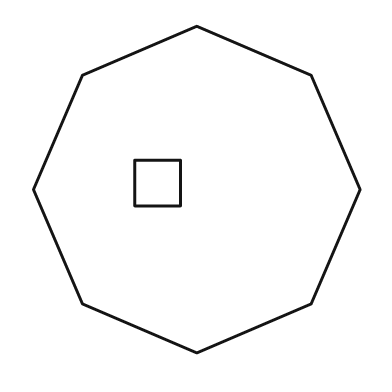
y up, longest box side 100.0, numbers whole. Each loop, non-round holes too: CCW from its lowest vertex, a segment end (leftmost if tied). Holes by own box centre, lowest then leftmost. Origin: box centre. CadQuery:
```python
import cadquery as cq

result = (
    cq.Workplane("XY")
    .moveTo(0.0, -50.0)
    .lineTo(35.0, -35.0)
    .lineTo(50.0, 0.0)
    .lineTo(35.0, 35.0)
    .lineTo(0.0, 50.0)
    .lineTo(-35.0, 35.0)
    .lineTo(-50.0, 0.0)
    .lineTo(-35.0, -35.0)
    .close()
    .moveTo(-19.0, -5.0)
    .lineTo(-5.0, -5.0)
    .lineTo(-5.0, 9.0)
    .lineTo(-19.0, 9.0)
    .close()
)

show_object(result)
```